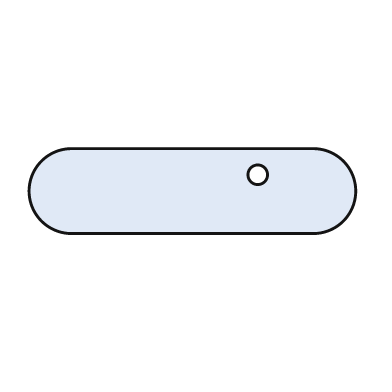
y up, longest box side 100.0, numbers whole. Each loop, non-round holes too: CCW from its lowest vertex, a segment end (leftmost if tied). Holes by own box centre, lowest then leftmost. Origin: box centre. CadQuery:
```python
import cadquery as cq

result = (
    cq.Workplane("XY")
    .moveTo(-37.0, -13.0)
    .lineTo(37.0, -13.0)
    .threePointArc((50.0, 0.0), (37.0, 13.0))
    .lineTo(-37.0, 13.0)
    .threePointArc((-50.0, 0.0), (-37.0, -13.0))
    .close()
    .moveTo(20.0, 5.0)
    .circle(3.0)
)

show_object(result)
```